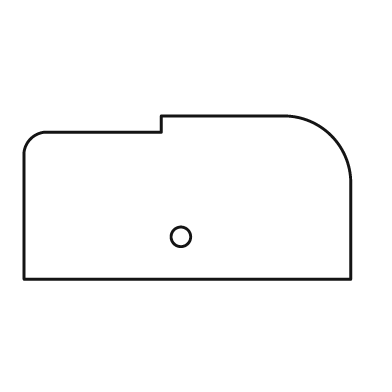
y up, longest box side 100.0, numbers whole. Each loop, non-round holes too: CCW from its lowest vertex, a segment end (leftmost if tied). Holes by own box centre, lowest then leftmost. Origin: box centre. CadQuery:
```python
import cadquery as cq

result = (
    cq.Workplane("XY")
    .moveTo(-50.0, -25.0)
    .lineTo(50.0, -25.0)
    .lineTo(50.0, 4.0)
    .threePointArc((44.0, 19.0), (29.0, 25.0))
    .lineTo(-8.0, 25.0)
    .lineTo(-8.0, 20.0)
    .lineTo(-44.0, 20.0)
    .threePointArc((-48.0, 18.0), (-50.0, 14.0))
    .close()
    .moveTo(-2.0, -12.0)
    .circle(3.0)
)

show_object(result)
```